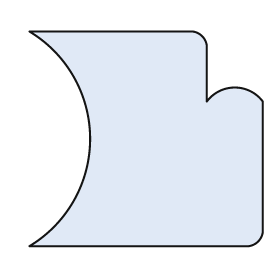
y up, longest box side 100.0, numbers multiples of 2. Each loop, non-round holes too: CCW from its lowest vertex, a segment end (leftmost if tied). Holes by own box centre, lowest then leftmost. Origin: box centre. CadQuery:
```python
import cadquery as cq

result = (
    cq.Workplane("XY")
    .moveTo(-50.0, -46.0)
    .lineTo(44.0, -46.0)
    .threePointArc((48.0, -44.0), (50.0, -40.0))
    .lineTo(50.0, 16.0)
    .threePointArc((38.0, 22.0), (26.0, 16.0))
    .lineTo(26.0, 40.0)
    .threePointArc((24.0, 44.0), (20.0, 46.0))
    .lineTo(-50.0, 46.0)
    .threePointArc((-24.0, 0.0), (-50.0, -46.0))
    .close()
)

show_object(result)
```